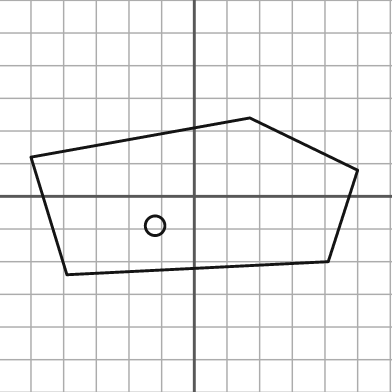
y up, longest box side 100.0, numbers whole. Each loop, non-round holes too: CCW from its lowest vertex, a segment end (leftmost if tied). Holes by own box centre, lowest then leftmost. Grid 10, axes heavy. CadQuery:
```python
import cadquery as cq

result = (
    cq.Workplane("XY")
    .moveTo(-39.0, -24.0)
    .lineTo(41.0, -20.0)
    .lineTo(50.0, 8.0)
    .lineTo(17.0, 24.0)
    .lineTo(-50.0, 12.0)
    .close()
    .moveTo(-12.0, -9.0)
    .circle(3.0)
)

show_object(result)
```